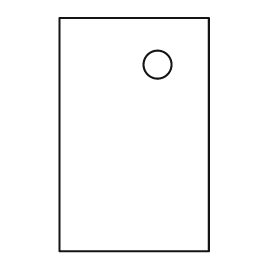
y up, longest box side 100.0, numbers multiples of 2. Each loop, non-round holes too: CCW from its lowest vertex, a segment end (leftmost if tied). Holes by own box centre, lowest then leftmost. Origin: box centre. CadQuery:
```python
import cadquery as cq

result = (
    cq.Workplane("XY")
    .moveTo(-32.0, -50.0)
    .lineTo(32.0, -50.0)
    .lineTo(32.0, 50.0)
    .lineTo(-32.0, 50.0)
    .close()
    .moveTo(10.0, 30.0)
    .circle(6.0)
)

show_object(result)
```